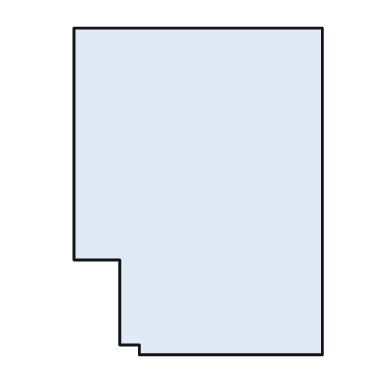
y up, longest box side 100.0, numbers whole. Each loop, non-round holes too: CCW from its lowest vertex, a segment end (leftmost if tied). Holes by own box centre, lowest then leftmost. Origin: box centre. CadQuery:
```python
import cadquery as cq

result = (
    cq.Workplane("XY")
    .moveTo(-18.0, -50.0)
    .lineTo(38.0, -50.0)
    .lineTo(38.0, 50.0)
    .lineTo(-38.0, 50.0)
    .lineTo(-38.0, -21.0)
    .lineTo(-24.0, -21.0)
    .lineTo(-24.0, -47.0)
    .lineTo(-18.0, -47.0)
    .close()
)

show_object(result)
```